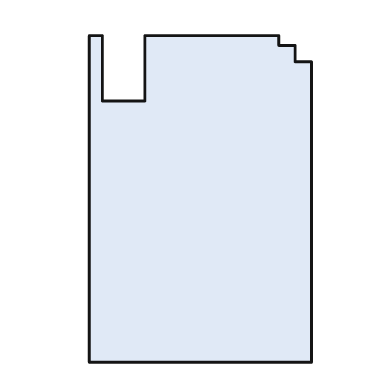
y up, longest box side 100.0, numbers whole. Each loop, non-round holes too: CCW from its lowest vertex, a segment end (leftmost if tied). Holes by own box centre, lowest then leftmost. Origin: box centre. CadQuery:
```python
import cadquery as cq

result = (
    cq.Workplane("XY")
    .moveTo(-34.0, -50.0)
    .lineTo(34.0, -50.0)
    .lineTo(34.0, 42.0)
    .lineTo(29.0, 42.0)
    .lineTo(29.0, 47.0)
    .lineTo(24.0, 47.0)
    .lineTo(24.0, 50.0)
    .lineTo(-17.0, 50.0)
    .lineTo(-17.0, 30.0)
    .lineTo(-30.0, 30.0)
    .lineTo(-30.0, 50.0)
    .lineTo(-34.0, 50.0)
    .close()
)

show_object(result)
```